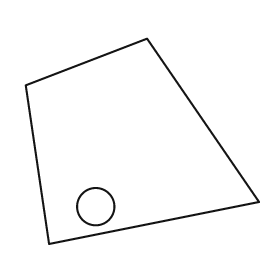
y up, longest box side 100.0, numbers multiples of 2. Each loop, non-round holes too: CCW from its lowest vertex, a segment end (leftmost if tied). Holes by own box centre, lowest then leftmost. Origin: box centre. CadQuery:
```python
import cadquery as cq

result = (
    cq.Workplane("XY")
    .moveTo(-40.0, -44.0)
    .lineTo(50.0, -26.0)
    .lineTo(2.0, 44.0)
    .lineTo(-50.0, 24.0)
    .close()
    .moveTo(-20.0, -28.0)
    .circle(8.0)
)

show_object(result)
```